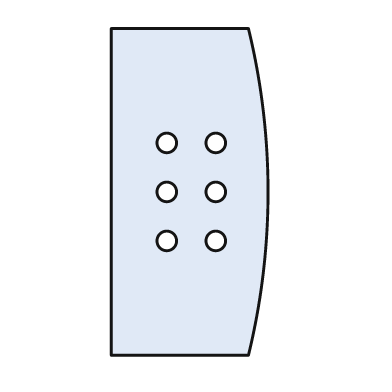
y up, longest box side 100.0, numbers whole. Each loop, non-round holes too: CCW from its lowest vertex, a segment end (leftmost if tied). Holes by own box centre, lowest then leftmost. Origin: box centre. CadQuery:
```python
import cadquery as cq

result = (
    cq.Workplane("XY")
    .moveTo(-24.0, -50.0)
    .lineTo(18.0, -50.0)
    .threePointArc((24.0, 0.0), (18.0, 50.0))
    .lineTo(-24.0, 50.0)
    .close()
    .moveTo(-7.0, -15.0)
    .circle(3.0)
    .moveTo(8.0, -15.0)
    .circle(3.0)
    .moveTo(-7.0, 0.0)
    .circle(3.0)
    .moveTo(8.0, 0.0)
    .circle(3.0)
    .moveTo(-7.0, 15.0)
    .circle(3.0)
    .moveTo(8.0, 15.0)
    .circle(3.0)
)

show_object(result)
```